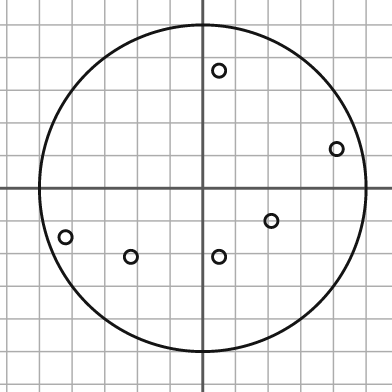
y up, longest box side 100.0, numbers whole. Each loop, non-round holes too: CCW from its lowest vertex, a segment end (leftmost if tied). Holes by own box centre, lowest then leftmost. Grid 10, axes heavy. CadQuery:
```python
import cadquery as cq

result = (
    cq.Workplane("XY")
    .moveTo(0.0, 0.0)
    .circle(50.0)
    .moveTo(-22.0, -21.0)
    .circle(2.0)
    .moveTo(5.0, -21.0)
    .circle(2.0)
    .moveTo(-42.0, -15.0)
    .circle(2.0)
    .moveTo(21.0, -10.0)
    .circle(2.0)
    .moveTo(41.0, 12.0)
    .circle(2.0)
    .moveTo(5.0, 36.0)
    .circle(2.0)
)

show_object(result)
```